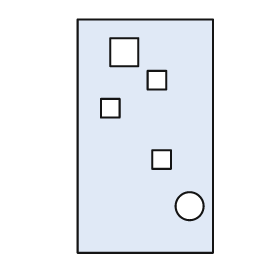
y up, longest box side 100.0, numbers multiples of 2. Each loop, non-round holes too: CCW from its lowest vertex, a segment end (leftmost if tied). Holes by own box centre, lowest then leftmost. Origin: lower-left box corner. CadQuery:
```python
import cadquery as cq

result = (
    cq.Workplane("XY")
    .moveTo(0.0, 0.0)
    .lineTo(58.0, 0.0)
    .lineTo(58.0, 100.0)
    .lineTo(0.0, 100.0)
    .close()
    .moveTo(48.0, 20.0)
    .circle(6.0)
    .moveTo(32.0, 36.0)
    .lineTo(40.0, 36.0)
    .lineTo(40.0, 44.0)
    .lineTo(32.0, 44.0)
    .close()
    .moveTo(10.0, 58.0)
    .lineTo(18.0, 58.0)
    .lineTo(18.0, 66.0)
    .lineTo(10.0, 66.0)
    .close()
    .moveTo(30.0, 70.0)
    .lineTo(38.0, 70.0)
    .lineTo(38.0, 78.0)
    .lineTo(30.0, 78.0)
    .close()
    .moveTo(14.0, 80.0)
    .lineTo(26.0, 80.0)
    .lineTo(26.0, 92.0)
    .lineTo(14.0, 92.0)
    .close()
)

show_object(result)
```